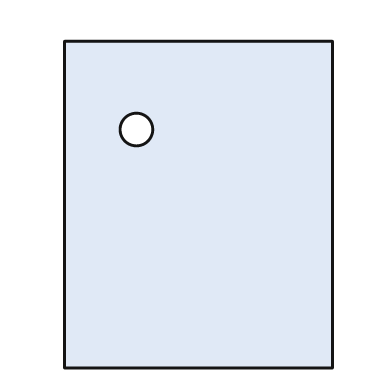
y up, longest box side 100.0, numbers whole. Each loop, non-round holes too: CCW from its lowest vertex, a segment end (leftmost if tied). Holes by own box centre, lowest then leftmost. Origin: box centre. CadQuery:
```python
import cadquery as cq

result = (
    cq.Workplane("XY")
    .moveTo(-41.0, -50.0)
    .lineTo(41.0, -50.0)
    .lineTo(41.0, 50.0)
    .lineTo(-41.0, 50.0)
    .close()
    .moveTo(-19.0, 23.0)
    .circle(5.0)
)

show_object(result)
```